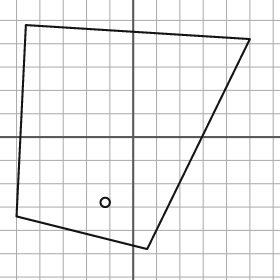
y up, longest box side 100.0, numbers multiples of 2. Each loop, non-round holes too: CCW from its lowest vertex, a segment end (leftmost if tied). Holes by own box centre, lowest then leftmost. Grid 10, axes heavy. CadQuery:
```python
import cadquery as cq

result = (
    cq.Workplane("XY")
    .moveTo(6.0, -48.0)
    .lineTo(50.0, 42.0)
    .lineTo(-46.0, 48.0)
    .lineTo(-50.0, -34.0)
    .close()
    .moveTo(-12.0, -28.0)
    .circle(2.0)
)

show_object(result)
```